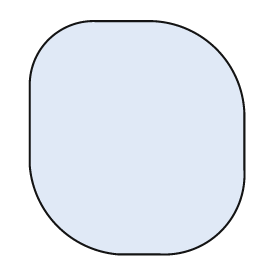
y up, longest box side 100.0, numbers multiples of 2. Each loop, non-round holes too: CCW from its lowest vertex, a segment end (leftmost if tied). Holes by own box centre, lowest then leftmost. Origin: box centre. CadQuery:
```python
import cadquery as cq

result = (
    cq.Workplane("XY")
    .moveTo(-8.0, -50.0)
    .lineTo(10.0, -50.0)
    .threePointArc((36.0, -40.0), (46.0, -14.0))
    .lineTo(46.0, 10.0)
    .threePointArc((34.0, 38.0), (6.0, 50.0))
    .lineTo(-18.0, 50.0)
    .threePointArc((-38.0, 42.0), (-46.0, 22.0))
    .lineTo(-46.0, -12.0)
    .threePointArc((-34.0, -38.0), (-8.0, -50.0))
    .close()
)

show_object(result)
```